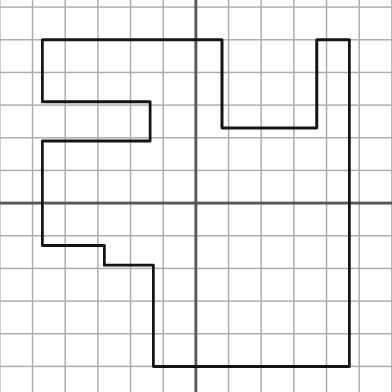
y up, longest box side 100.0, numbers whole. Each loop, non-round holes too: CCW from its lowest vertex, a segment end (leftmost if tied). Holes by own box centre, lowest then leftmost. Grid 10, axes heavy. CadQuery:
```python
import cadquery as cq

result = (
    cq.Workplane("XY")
    .moveTo(-13.0, -50.0)
    .lineTo(47.0, -50.0)
    .lineTo(47.0, 50.0)
    .lineTo(37.0, 50.0)
    .lineTo(37.0, 23.0)
    .lineTo(8.0, 23.0)
    .lineTo(8.0, 50.0)
    .lineTo(-47.0, 50.0)
    .lineTo(-47.0, 31.0)
    .lineTo(-14.0, 31.0)
    .lineTo(-14.0, 19.0)
    .lineTo(-47.0, 19.0)
    .lineTo(-47.0, -13.0)
    .lineTo(-28.0, -13.0)
    .lineTo(-28.0, -19.0)
    .lineTo(-13.0, -19.0)
    .close()
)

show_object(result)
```